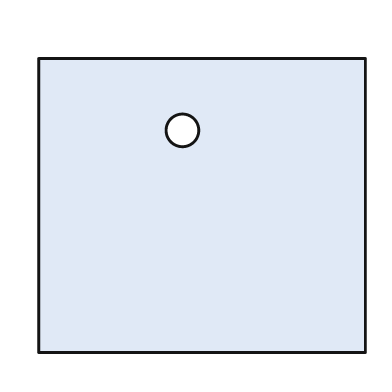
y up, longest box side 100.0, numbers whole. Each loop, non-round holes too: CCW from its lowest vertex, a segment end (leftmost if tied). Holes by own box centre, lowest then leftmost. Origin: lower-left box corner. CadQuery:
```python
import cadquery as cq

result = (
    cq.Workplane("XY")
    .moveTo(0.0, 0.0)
    .lineTo(100.0, 0.0)
    .lineTo(100.0, 90.0)
    .lineTo(0.0, 90.0)
    .close()
    .moveTo(44.0, 68.0)
    .circle(5.0)
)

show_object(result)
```